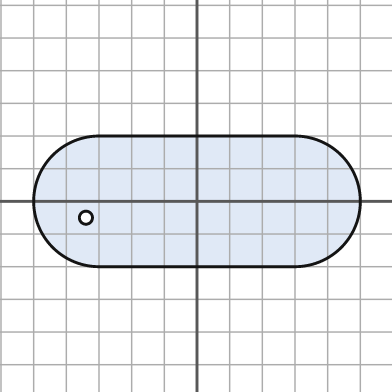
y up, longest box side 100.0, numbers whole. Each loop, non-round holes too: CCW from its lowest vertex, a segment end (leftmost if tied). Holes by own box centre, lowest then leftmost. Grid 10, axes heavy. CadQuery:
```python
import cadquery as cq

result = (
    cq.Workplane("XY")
    .moveTo(-30.0, -20.0)
    .lineTo(30.0, -20.0)
    .threePointArc((50.0, 0.0), (30.0, 20.0))
    .lineTo(-30.0, 20.0)
    .threePointArc((-50.0, 0.0), (-30.0, -20.0))
    .close()
    .moveTo(-34.0, -5.0)
    .circle(2.0)
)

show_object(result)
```